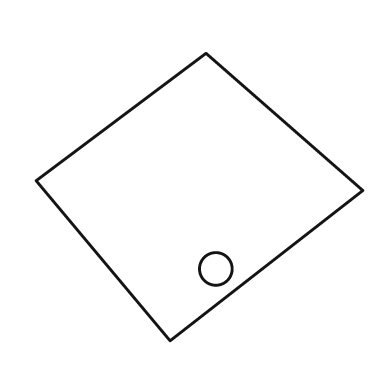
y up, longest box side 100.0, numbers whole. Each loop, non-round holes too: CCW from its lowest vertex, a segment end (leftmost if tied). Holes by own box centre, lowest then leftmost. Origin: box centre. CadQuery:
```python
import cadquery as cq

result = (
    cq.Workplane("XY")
    .moveTo(-9.0, -44.0)
    .lineTo(50.0, 2.0)
    .lineTo(2.0, 44.0)
    .lineTo(-50.0, 5.0)
    .close()
    .moveTo(5.0, -22.0)
    .circle(5.0)
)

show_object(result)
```